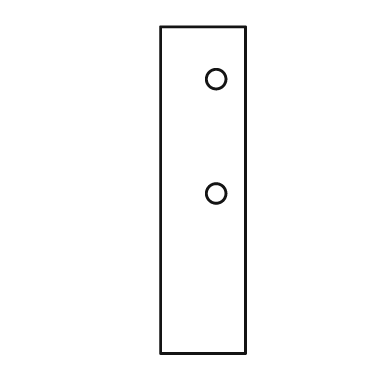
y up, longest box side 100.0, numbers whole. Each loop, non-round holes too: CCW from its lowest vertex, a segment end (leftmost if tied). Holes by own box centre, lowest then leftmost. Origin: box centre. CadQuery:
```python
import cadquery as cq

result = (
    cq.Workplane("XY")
    .moveTo(-13.0, -50.0)
    .lineTo(13.0, -50.0)
    .lineTo(13.0, 50.0)
    .lineTo(-13.0, 50.0)
    .close()
    .moveTo(4.0, -1.0)
    .circle(3.0)
    .moveTo(4.0, 34.0)
    .circle(3.0)
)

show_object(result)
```